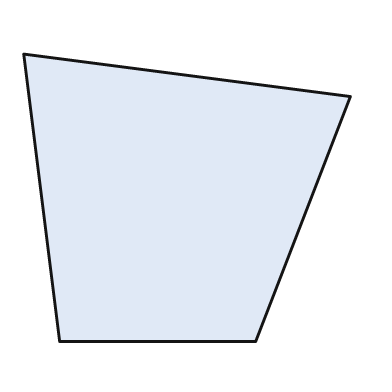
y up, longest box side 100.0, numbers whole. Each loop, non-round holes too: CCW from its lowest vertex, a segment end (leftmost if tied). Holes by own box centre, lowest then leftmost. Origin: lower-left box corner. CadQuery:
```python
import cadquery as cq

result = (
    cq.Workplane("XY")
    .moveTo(11.0, 0.0)
    .lineTo(71.0, 0.0)
    .lineTo(100.0, 75.0)
    .lineTo(0.0, 88.0)
    .close()
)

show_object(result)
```